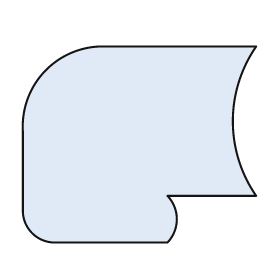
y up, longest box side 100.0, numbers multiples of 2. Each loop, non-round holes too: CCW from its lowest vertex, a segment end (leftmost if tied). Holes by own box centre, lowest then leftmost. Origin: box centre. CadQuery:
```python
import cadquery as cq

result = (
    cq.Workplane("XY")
    .moveTo(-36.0, -42.0)
    .lineTo(12.0, -42.0)
    .threePointArc((16.0, -32.0), (12.0, -22.0))
    .lineTo(50.0, -22.0)
    .threePointArc((40.0, 10.0), (50.0, 42.0))
    .lineTo(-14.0, 42.0)
    .threePointArc((-40.0, 32.0), (-50.0, 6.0))
    .lineTo(-50.0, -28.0)
    .threePointArc((-46.0, -38.0), (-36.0, -42.0))
    .close()
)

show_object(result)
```